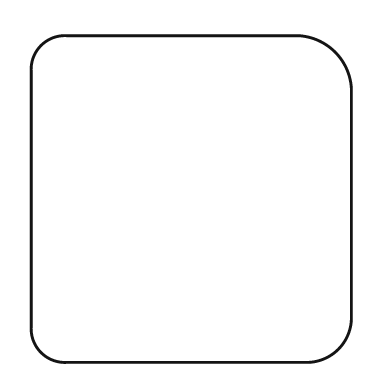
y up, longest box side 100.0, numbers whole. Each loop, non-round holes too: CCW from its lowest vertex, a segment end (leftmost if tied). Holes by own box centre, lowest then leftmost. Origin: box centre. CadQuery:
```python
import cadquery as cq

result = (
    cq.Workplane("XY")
    .moveTo(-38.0, -50.0)
    .lineTo(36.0, -50.0)
    .threePointArc((45.0, -46.0), (49.0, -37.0))
    .lineTo(49.0, 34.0)
    .threePointArc((44.0, 45.0), (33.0, 50.0))
    .lineTo(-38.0, 50.0)
    .threePointArc((-46.0, 47.0), (-49.0, 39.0))
    .lineTo(-49.0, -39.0)
    .threePointArc((-46.0, -47.0), (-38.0, -50.0))
    .close()
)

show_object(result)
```